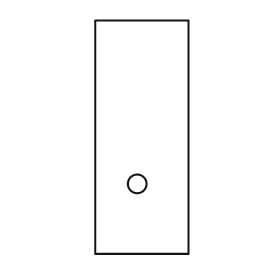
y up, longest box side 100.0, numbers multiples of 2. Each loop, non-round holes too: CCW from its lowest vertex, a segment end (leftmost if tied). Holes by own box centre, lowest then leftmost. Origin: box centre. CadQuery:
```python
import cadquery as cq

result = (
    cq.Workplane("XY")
    .moveTo(-20.0, -50.0)
    .lineTo(20.0, -50.0)
    .lineTo(20.0, 50.0)
    .lineTo(-20.0, 50.0)
    .close()
    .moveTo(-2.0, -20.0)
    .circle(4.0)
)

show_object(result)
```